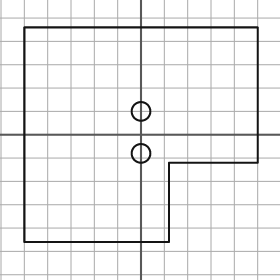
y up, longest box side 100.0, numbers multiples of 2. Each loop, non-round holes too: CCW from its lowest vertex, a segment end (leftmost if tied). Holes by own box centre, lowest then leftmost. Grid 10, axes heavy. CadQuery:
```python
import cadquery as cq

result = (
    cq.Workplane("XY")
    .moveTo(-50.0, -46.0)
    .lineTo(12.0, -46.0)
    .lineTo(12.0, -12.0)
    .lineTo(50.0, -12.0)
    .lineTo(50.0, 46.0)
    .lineTo(-50.0, 46.0)
    .close()
    .moveTo(0.0, -8.0)
    .circle(4.0)
    .moveTo(0.0, 10.0)
    .circle(4.0)
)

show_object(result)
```